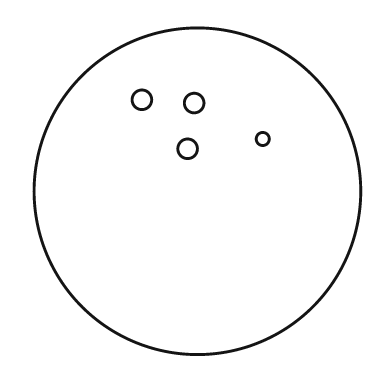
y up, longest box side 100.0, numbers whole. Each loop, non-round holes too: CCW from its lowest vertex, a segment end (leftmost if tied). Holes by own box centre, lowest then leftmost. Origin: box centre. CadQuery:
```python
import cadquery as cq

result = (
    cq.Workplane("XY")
    .moveTo(0.0, 0.0)
    .circle(50.0)
    .moveTo(-3.0, 13.0)
    .circle(3.0)
    .moveTo(20.0, 16.0)
    .circle(2.0)
    .moveTo(-1.0, 27.0)
    .circle(3.0)
    .moveTo(-17.0, 28.0)
    .circle(3.0)
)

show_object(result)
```